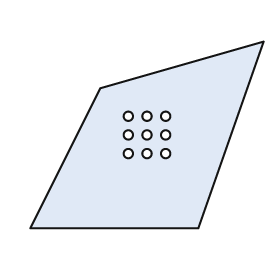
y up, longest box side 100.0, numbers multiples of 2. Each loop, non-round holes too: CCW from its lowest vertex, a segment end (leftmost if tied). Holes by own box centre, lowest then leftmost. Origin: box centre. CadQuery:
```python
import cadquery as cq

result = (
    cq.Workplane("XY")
    .moveTo(-50.0, -40.0)
    .lineTo(22.0, -40.0)
    .lineTo(50.0, 40.0)
    .lineTo(-20.0, 20.0)
    .close()
    .moveTo(-8.0, -8.0)
    .circle(2.0)
    .moveTo(0.0, -8.0)
    .circle(2.0)
    .moveTo(8.0, -8.0)
    .circle(2.0)
    .moveTo(-8.0, 0.0)
    .circle(2.0)
    .moveTo(0.0, 0.0)
    .circle(2.0)
    .moveTo(8.0, 0.0)
    .circle(2.0)
    .moveTo(-8.0, 8.0)
    .circle(2.0)
    .moveTo(0.0, 8.0)
    .circle(2.0)
    .moveTo(8.0, 8.0)
    .circle(2.0)
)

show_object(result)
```